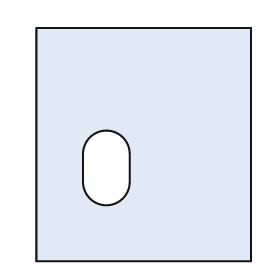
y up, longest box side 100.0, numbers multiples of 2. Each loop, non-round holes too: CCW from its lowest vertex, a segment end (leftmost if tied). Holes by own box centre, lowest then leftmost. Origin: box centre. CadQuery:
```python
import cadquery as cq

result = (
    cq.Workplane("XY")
    .moveTo(-46.0, -50.0)
    .lineTo(46.0, -50.0)
    .lineTo(46.0, 50.0)
    .lineTo(-46.0, 50.0)
    .close()
    .moveTo(-26.0, -16.0)
    .threePointArc((-16.0, -26.0), (-6.0, -16.0))
    .lineTo(-6.0, -4.0)
    .threePointArc((-16.0, 6.0), (-26.0, -4.0))
    .close()
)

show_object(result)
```